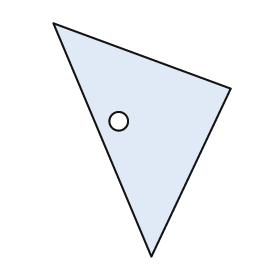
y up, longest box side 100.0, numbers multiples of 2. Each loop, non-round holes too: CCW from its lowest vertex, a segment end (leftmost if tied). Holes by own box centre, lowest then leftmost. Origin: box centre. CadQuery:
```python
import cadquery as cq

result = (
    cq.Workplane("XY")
    .moveTo(4.0, -50.0)
    .lineTo(38.0, 22.0)
    .lineTo(-38.0, 50.0)
    .close()
    .moveTo(-10.0, 8.0)
    .circle(4.0)
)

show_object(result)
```